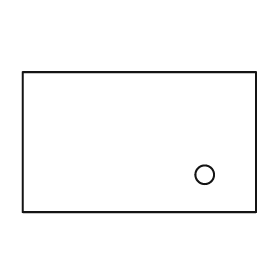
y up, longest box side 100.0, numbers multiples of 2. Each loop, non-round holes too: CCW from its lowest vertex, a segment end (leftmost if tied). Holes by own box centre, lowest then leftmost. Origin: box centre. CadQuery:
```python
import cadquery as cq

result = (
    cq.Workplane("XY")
    .moveTo(-50.0, -30.0)
    .lineTo(50.0, -30.0)
    .lineTo(50.0, 30.0)
    .lineTo(-50.0, 30.0)
    .close()
    .moveTo(28.0, -14.0)
    .circle(4.0)
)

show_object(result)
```